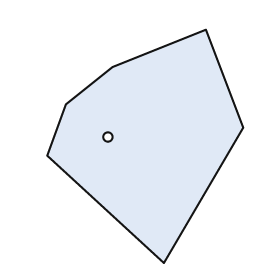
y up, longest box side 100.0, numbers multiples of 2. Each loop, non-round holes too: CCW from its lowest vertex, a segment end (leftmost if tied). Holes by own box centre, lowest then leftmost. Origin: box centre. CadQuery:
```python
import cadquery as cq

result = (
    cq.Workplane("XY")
    .moveTo(8.0, -50.0)
    .lineTo(42.0, 8.0)
    .lineTo(26.0, 50.0)
    .lineTo(-14.0, 34.0)
    .lineTo(-34.0, 18.0)
    .lineTo(-42.0, -4.0)
    .close()
    .moveTo(-16.0, 4.0)
    .circle(2.0)
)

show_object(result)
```